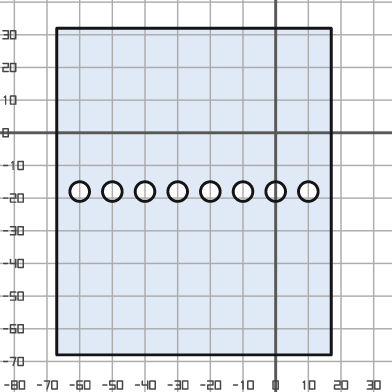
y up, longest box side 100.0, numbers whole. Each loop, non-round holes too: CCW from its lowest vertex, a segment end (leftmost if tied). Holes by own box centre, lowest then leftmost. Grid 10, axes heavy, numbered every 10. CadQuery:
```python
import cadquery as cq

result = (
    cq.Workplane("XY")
    .moveTo(-67.0, -68.0)
    .lineTo(17.0, -68.0)
    .lineTo(17.0, 32.0)
    .lineTo(-67.0, 32.0)
    .close()
    .moveTo(-60.0, -18.0)
    .circle(3.0)
    .moveTo(-50.0, -18.0)
    .circle(3.0)
    .moveTo(-40.0, -18.0)
    .circle(3.0)
    .moveTo(-30.0, -18.0)
    .circle(3.0)
    .moveTo(-20.0, -18.0)
    .circle(3.0)
    .moveTo(-10.0, -18.0)
    .circle(3.0)
    .moveTo(0.0, -18.0)
    .circle(3.0)
    .moveTo(10.0, -18.0)
    .circle(3.0)
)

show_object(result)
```